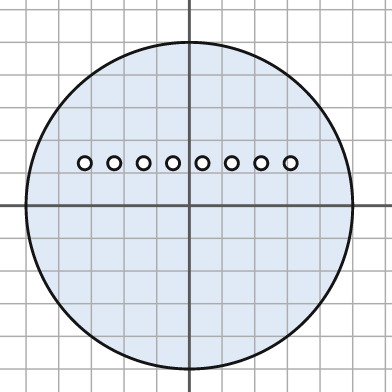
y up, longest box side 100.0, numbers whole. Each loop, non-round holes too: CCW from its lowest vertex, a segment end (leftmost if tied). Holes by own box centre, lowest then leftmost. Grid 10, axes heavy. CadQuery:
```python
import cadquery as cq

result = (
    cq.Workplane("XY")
    .moveTo(0.0, 0.0)
    .circle(50.0)
    .moveTo(-32.0, 13.0)
    .circle(2.0)
    .moveTo(-23.0, 13.0)
    .circle(2.0)
    .moveTo(-14.0, 13.0)
    .circle(2.0)
    .moveTo(-5.0, 13.0)
    .circle(2.0)
    .moveTo(4.0, 13.0)
    .circle(2.0)
    .moveTo(13.0, 13.0)
    .circle(2.0)
    .moveTo(22.0, 13.0)
    .circle(2.0)
    .moveTo(31.0, 13.0)
    .circle(2.0)
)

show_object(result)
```